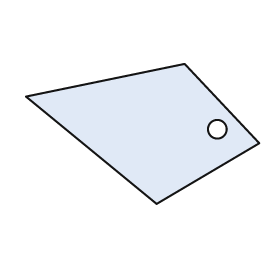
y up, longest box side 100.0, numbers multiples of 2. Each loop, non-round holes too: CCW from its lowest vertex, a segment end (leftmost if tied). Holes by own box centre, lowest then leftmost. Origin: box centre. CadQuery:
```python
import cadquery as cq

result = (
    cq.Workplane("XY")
    .moveTo(6.0, -30.0)
    .lineTo(50.0, -4.0)
    .lineTo(18.0, 30.0)
    .lineTo(-50.0, 16.0)
    .close()
    .moveTo(32.0, 2.0)
    .circle(4.0)
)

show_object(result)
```